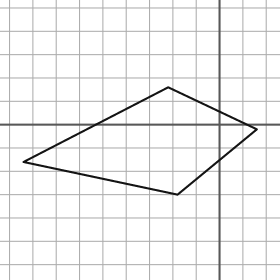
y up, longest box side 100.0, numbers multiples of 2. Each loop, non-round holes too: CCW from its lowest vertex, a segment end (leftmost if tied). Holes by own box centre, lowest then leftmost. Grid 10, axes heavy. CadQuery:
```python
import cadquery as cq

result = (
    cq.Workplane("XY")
    .moveTo(-18.0, -30.0)
    .lineTo(16.0, -2.0)
    .lineTo(-22.0, 16.0)
    .lineTo(-84.0, -16.0)
    .close()
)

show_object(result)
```